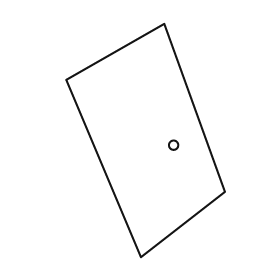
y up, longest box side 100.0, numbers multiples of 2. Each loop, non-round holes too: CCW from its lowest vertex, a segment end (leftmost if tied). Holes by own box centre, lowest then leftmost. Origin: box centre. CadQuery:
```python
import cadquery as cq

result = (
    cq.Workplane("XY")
    .moveTo(-2.0, -50.0)
    .lineTo(34.0, -22.0)
    .lineTo(8.0, 50.0)
    .lineTo(-34.0, 26.0)
    .close()
    .moveTo(12.0, -2.0)
    .circle(2.0)
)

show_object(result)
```